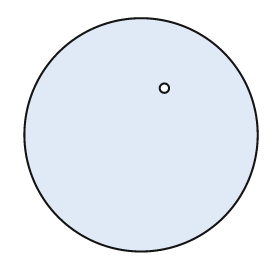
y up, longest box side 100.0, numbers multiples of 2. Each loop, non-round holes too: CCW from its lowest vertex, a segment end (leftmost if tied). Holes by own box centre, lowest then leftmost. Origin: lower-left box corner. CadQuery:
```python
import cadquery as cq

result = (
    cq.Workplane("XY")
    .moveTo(50.0, 50.0)
    .circle(50.0)
    .moveTo(60.0, 70.0)
    .circle(2.0)
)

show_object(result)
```